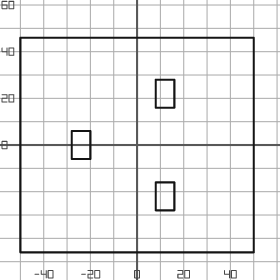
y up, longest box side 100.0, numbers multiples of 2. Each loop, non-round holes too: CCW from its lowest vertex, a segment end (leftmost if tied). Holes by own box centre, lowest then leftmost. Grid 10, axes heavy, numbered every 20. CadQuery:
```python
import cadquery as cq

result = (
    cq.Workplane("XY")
    .moveTo(-50.0, -46.0)
    .lineTo(50.0, -46.0)
    .lineTo(50.0, 46.0)
    .lineTo(-50.0, 46.0)
    .close()
    .moveTo(8.0, -28.0)
    .lineTo(16.0, -28.0)
    .lineTo(16.0, -16.0)
    .lineTo(8.0, -16.0)
    .close()
    .moveTo(-28.0, -6.0)
    .lineTo(-20.0, -6.0)
    .lineTo(-20.0, 6.0)
    .lineTo(-28.0, 6.0)
    .close()
    .moveTo(8.0, 16.0)
    .lineTo(16.0, 16.0)
    .lineTo(16.0, 28.0)
    .lineTo(8.0, 28.0)
    .close()
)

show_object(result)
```